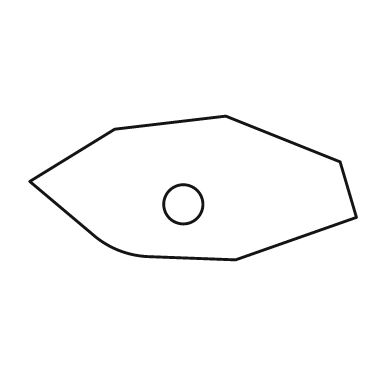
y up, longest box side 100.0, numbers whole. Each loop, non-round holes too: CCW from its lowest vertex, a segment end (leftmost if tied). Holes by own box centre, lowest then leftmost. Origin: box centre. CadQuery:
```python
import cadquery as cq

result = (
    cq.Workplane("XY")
    .moveTo(13.0, -22.0)
    .lineTo(50.0, -9.0)
    .lineTo(45.0, 8.0)
    .lineTo(10.0, 22.0)
    .lineTo(-24.0, 18.0)
    .lineTo(-50.0, 2.0)
    .lineTo(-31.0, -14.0)
    .threePointArc((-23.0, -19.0), (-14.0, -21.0))
    .close()
    .moveTo(-3.0, -5.0)
    .circle(6.0)
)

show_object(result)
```